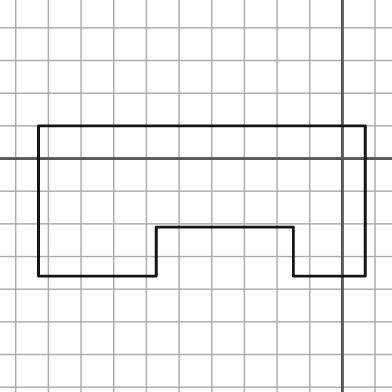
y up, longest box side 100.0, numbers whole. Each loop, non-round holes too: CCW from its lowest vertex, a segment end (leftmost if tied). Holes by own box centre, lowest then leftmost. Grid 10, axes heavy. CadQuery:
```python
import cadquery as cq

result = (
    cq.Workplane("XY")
    .moveTo(-93.0, -36.0)
    .lineTo(-57.0, -36.0)
    .lineTo(-57.0, -21.0)
    .lineTo(-15.0, -21.0)
    .lineTo(-15.0, -36.0)
    .lineTo(7.0, -36.0)
    .lineTo(7.0, 10.0)
    .lineTo(-93.0, 10.0)
    .close()
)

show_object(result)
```